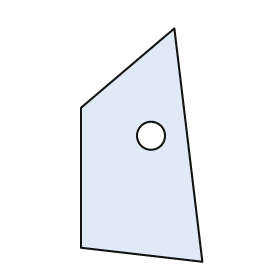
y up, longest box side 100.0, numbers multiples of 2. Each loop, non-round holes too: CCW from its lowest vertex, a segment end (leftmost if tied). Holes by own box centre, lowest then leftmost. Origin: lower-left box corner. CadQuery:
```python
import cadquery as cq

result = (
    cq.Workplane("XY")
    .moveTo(52.0, 0.0)
    .lineTo(40.0, 100.0)
    .lineTo(0.0, 66.0)
    .lineTo(0.0, 6.0)
    .close()
    .moveTo(30.0, 54.0)
    .circle(6.0)
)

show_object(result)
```